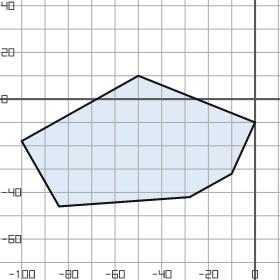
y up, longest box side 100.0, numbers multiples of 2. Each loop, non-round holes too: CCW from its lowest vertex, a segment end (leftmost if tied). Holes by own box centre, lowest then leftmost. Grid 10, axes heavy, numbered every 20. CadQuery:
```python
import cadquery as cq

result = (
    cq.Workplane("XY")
    .moveTo(-84.0, -46.0)
    .lineTo(-28.0, -42.0)
    .lineTo(-10.0, -32.0)
    .lineTo(0.0, -10.0)
    .lineTo(-50.0, 10.0)
    .lineTo(-100.0, -18.0)
    .close()
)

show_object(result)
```